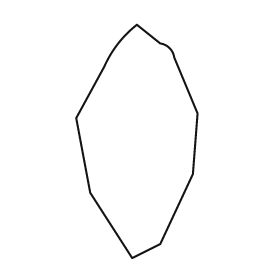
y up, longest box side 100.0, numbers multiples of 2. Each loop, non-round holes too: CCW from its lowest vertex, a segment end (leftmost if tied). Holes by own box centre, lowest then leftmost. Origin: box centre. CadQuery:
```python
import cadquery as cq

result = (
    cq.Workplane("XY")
    .moveTo(-2.0, -50.0)
    .lineTo(10.0, -44.0)
    .lineTo(24.0, -14.0)
    .lineTo(26.0, 12.0)
    .lineTo(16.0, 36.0)
    .threePointArc((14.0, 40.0), (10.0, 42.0))
    .lineTo(0.0, 50.0)
    .threePointArc((-8.0, 42.0), (-14.0, 32.0))
    .lineTo(-26.0, 10.0)
    .lineTo(-20.0, -22.0)
    .close()
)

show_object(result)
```